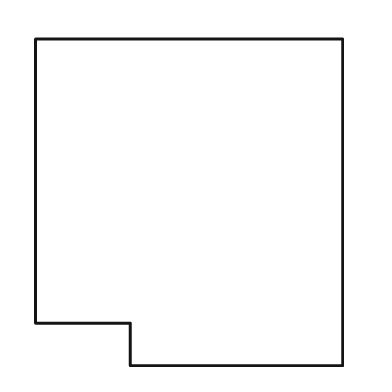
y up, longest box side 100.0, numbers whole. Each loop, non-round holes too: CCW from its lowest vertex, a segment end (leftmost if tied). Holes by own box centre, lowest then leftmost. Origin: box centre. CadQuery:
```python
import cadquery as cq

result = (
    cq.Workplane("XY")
    .moveTo(-18.0, -50.0)
    .lineTo(47.0, -50.0)
    .lineTo(47.0, 50.0)
    .lineTo(-47.0, 50.0)
    .lineTo(-47.0, -37.0)
    .lineTo(-18.0, -37.0)
    .close()
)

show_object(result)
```